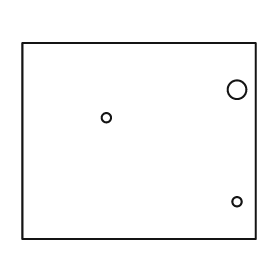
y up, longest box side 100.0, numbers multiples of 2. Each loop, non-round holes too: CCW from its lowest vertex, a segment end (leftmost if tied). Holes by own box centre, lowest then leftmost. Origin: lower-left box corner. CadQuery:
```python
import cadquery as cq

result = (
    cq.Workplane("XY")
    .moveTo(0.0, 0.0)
    .lineTo(100.0, 0.0)
    .lineTo(100.0, 84.0)
    .lineTo(0.0, 84.0)
    .close()
    .moveTo(92.0, 16.0)
    .circle(2.0)
    .moveTo(36.0, 52.0)
    .circle(2.0)
    .moveTo(92.0, 64.0)
    .circle(4.0)
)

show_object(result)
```